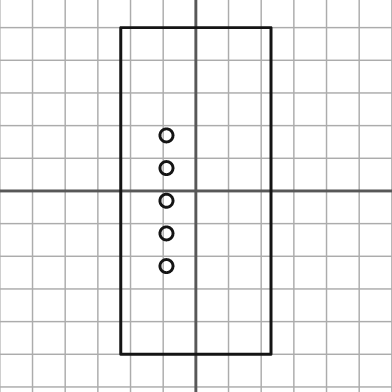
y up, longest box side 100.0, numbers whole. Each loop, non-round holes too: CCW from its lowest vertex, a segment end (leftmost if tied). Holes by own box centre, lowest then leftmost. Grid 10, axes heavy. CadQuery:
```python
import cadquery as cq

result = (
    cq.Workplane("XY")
    .moveTo(-23.0, -50.0)
    .lineTo(23.0, -50.0)
    .lineTo(23.0, 50.0)
    .lineTo(-23.0, 50.0)
    .close()
    .moveTo(-9.0, -23.0)
    .circle(2.0)
    .moveTo(-9.0, -13.0)
    .circle(2.0)
    .moveTo(-9.0, -3.0)
    .circle(2.0)
    .moveTo(-9.0, 7.0)
    .circle(2.0)
    .moveTo(-9.0, 17.0)
    .circle(2.0)
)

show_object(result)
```